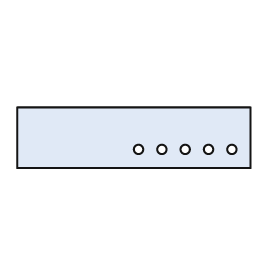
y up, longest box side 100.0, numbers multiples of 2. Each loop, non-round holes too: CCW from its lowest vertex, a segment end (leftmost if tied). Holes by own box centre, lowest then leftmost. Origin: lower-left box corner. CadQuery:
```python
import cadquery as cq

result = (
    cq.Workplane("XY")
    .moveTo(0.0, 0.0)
    .lineTo(100.0, 0.0)
    .lineTo(100.0, 26.0)
    .lineTo(0.0, 26.0)
    .close()
    .moveTo(52.0, 8.0)
    .circle(2.0)
    .moveTo(62.0, 8.0)
    .circle(2.0)
    .moveTo(72.0, 8.0)
    .circle(2.0)
    .moveTo(82.0, 8.0)
    .circle(2.0)
    .moveTo(92.0, 8.0)
    .circle(2.0)
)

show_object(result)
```